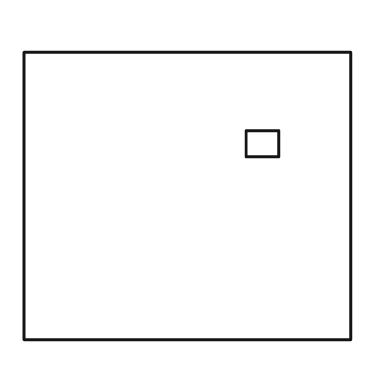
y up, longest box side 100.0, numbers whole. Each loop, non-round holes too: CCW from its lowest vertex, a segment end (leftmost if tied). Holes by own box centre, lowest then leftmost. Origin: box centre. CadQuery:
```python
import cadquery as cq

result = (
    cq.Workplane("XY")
    .moveTo(-50.0, -44.0)
    .lineTo(50.0, -44.0)
    .lineTo(50.0, 44.0)
    .lineTo(-50.0, 44.0)
    .close()
    .moveTo(18.0, 12.0)
    .lineTo(28.0, 12.0)
    .lineTo(28.0, 20.0)
    .lineTo(18.0, 20.0)
    .close()
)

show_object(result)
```